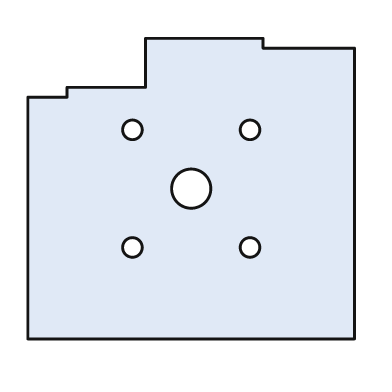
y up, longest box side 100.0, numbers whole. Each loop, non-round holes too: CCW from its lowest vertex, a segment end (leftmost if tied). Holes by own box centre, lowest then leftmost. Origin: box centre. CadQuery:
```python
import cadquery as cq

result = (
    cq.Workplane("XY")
    .moveTo(-50.0, -46.0)
    .lineTo(50.0, -46.0)
    .lineTo(50.0, 43.0)
    .lineTo(22.0, 43.0)
    .lineTo(22.0, 46.0)
    .lineTo(-14.0, 46.0)
    .lineTo(-14.0, 31.0)
    .lineTo(-38.0, 31.0)
    .lineTo(-38.0, 28.0)
    .lineTo(-50.0, 28.0)
    .close()
    .moveTo(-18.0, -18.0)
    .circle(3.0)
    .moveTo(18.0, -18.0)
    .circle(3.0)
    .moveTo(0.0, 0.0)
    .circle(6.0)
    .moveTo(-18.0, 18.0)
    .circle(3.0)
    .moveTo(18.0, 18.0)
    .circle(3.0)
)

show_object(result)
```